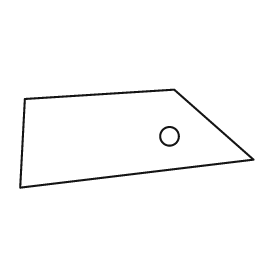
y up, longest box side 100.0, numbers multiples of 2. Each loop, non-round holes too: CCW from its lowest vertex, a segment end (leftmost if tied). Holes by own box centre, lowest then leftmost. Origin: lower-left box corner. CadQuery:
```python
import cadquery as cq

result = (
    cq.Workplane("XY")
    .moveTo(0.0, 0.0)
    .lineTo(100.0, 12.0)
    .lineTo(66.0, 42.0)
    .lineTo(2.0, 38.0)
    .close()
    .moveTo(64.0, 22.0)
    .circle(4.0)
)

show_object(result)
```